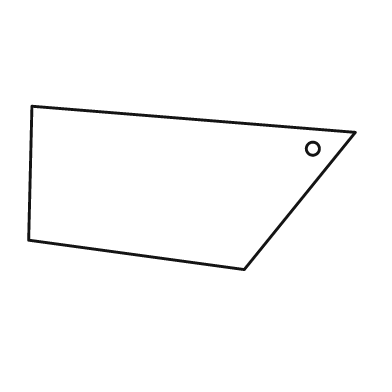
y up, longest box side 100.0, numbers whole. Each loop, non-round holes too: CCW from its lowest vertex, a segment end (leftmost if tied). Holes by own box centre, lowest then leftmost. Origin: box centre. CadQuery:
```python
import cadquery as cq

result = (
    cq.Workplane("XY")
    .moveTo(16.0, -25.0)
    .lineTo(50.0, 17.0)
    .lineTo(-49.0, 25.0)
    .lineTo(-50.0, -16.0)
    .close()
    .moveTo(37.0, 12.0)
    .circle(2.0)
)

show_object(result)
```